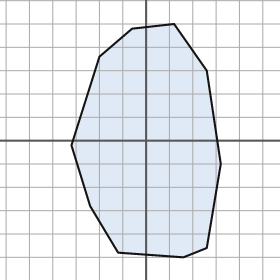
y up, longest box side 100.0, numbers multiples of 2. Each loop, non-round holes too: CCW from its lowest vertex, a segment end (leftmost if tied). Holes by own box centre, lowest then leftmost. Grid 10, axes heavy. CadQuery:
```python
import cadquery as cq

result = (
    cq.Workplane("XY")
    .moveTo(16.0, -50.0)
    .lineTo(26.0, -46.0)
    .lineTo(32.0, -10.0)
    .lineTo(26.0, 30.0)
    .lineTo(12.0, 50.0)
    .lineTo(-6.0, 48.0)
    .lineTo(-20.0, 36.0)
    .lineTo(-32.0, -2.0)
    .lineTo(-24.0, -28.0)
    .lineTo(-12.0, -48.0)
    .close()
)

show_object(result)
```